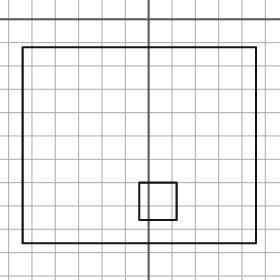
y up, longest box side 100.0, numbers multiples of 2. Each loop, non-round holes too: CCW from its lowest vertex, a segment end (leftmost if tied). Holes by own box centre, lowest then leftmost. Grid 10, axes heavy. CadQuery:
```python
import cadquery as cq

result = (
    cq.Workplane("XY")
    .moveTo(-54.0, -96.0)
    .lineTo(46.0, -96.0)
    .lineTo(46.0, -12.0)
    .lineTo(-54.0, -12.0)
    .close()
    .moveTo(-4.0, -86.0)
    .lineTo(12.0, -86.0)
    .lineTo(12.0, -70.0)
    .lineTo(-4.0, -70.0)
    .close()
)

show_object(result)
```